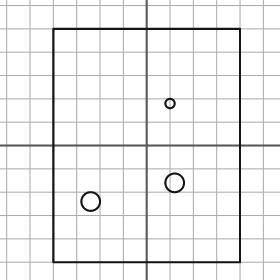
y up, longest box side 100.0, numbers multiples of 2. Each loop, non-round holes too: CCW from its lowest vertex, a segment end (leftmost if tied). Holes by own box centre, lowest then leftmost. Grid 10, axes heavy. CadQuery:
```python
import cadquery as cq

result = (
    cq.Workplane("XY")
    .moveTo(-40.0, -50.0)
    .lineTo(40.0, -50.0)
    .lineTo(40.0, 50.0)
    .lineTo(-40.0, 50.0)
    .close()
    .moveTo(-24.0, -24.0)
    .circle(4.0)
    .moveTo(12.0, -16.0)
    .circle(4.0)
    .moveTo(10.0, 18.0)
    .circle(2.0)
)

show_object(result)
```